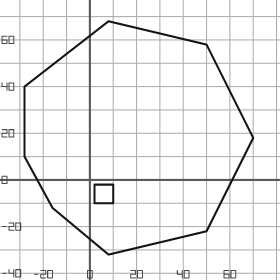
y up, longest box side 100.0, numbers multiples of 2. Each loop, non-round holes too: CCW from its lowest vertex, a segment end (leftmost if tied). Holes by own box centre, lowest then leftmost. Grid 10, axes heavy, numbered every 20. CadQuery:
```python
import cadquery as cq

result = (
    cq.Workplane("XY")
    .moveTo(8.0, -32.0)
    .lineTo(50.0, -22.0)
    .lineTo(70.0, 18.0)
    .lineTo(50.0, 58.0)
    .lineTo(8.0, 68.0)
    .lineTo(-28.0, 40.0)
    .lineTo(-28.0, 10.0)
    .lineTo(-16.0, -12.0)
    .close()
    .moveTo(2.0, -10.0)
    .lineTo(10.0, -10.0)
    .lineTo(10.0, -2.0)
    .lineTo(2.0, -2.0)
    .close()
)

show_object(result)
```